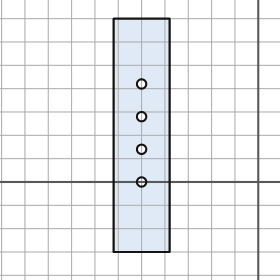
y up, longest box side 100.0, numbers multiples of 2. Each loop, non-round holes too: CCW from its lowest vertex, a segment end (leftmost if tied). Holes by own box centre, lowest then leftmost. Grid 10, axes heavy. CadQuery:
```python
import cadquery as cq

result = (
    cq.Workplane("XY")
    .moveTo(-62.0, -30.0)
    .lineTo(-38.0, -30.0)
    .lineTo(-38.0, 70.0)
    .lineTo(-62.0, 70.0)
    .close()
    .moveTo(-50.0, 0.0)
    .circle(2.0)
    .moveTo(-50.0, 14.0)
    .circle(2.0)
    .moveTo(-50.0, 28.0)
    .circle(2.0)
    .moveTo(-50.0, 42.0)
    .circle(2.0)
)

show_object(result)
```